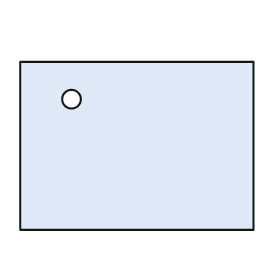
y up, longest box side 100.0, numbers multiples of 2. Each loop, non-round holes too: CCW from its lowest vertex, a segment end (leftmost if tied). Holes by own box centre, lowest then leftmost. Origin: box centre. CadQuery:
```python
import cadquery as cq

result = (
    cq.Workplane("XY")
    .moveTo(-50.0, -36.0)
    .lineTo(50.0, -36.0)
    .lineTo(50.0, 36.0)
    .lineTo(-50.0, 36.0)
    .close()
    .moveTo(-28.0, 20.0)
    .circle(4.0)
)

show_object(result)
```